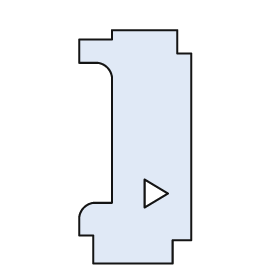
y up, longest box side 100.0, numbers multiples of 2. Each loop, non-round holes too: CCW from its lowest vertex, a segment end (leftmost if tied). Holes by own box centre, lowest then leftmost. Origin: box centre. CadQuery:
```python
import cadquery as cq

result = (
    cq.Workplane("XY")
    .moveTo(-18.0, -50.0)
    .lineTo(16.0, -50.0)
    .lineTo(16.0, -40.0)
    .lineTo(24.0, -40.0)
    .lineTo(24.0, 40.0)
    .lineTo(18.0, 40.0)
    .lineTo(18.0, 50.0)
    .lineTo(-10.0, 50.0)
    .lineTo(-10.0, 46.0)
    .lineTo(-24.0, 46.0)
    .lineTo(-24.0, 36.0)
    .lineTo(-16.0, 36.0)
    .threePointArc((-12.0, 34.0), (-10.0, 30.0))
    .lineTo(-10.0, -24.0)
    .lineTo(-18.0, -24.0)
    .threePointArc((-22.0, -26.0), (-24.0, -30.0))
    .lineTo(-24.0, -38.0)
    .lineTo(-18.0, -38.0)
    .close()
    .moveTo(4.0, -26.0)
    .lineTo(14.0, -20.0)
    .lineTo(4.0, -14.0)
    .close()
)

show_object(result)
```